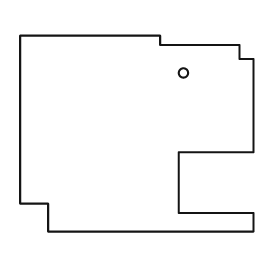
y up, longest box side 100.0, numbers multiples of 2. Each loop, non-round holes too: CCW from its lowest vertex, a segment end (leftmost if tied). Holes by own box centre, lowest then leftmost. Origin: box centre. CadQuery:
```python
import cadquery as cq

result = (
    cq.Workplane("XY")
    .moveTo(-38.0, -42.0)
    .lineTo(50.0, -42.0)
    .lineTo(50.0, -34.0)
    .lineTo(18.0, -34.0)
    .lineTo(18.0, -8.0)
    .lineTo(50.0, -8.0)
    .lineTo(50.0, 32.0)
    .lineTo(44.0, 32.0)
    .lineTo(44.0, 38.0)
    .lineTo(10.0, 38.0)
    .lineTo(10.0, 42.0)
    .lineTo(-50.0, 42.0)
    .lineTo(-50.0, -30.0)
    .lineTo(-38.0, -30.0)
    .close()
    .moveTo(20.0, 26.0)
    .circle(2.0)
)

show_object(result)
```